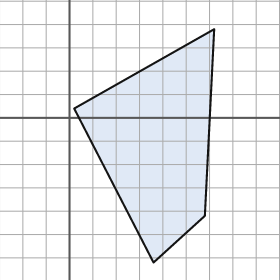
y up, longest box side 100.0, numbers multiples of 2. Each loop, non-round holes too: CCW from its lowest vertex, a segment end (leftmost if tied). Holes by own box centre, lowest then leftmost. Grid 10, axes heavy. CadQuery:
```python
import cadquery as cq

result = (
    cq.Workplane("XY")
    .moveTo(36.0, -62.0)
    .lineTo(58.0, -42.0)
    .lineTo(62.0, 38.0)
    .lineTo(2.0, 4.0)
    .close()
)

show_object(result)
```